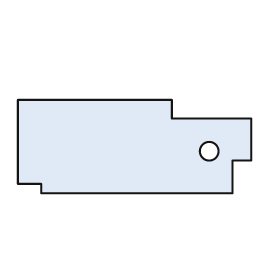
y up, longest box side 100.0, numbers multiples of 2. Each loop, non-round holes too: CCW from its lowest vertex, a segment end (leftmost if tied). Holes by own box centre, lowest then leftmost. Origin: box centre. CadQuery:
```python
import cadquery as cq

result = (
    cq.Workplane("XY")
    .moveTo(-40.0, -20.0)
    .lineTo(42.0, -20.0)
    .lineTo(42.0, -6.0)
    .lineTo(50.0, -6.0)
    .lineTo(50.0, 12.0)
    .lineTo(16.0, 12.0)
    .lineTo(16.0, 20.0)
    .lineTo(-50.0, 20.0)
    .lineTo(-50.0, -16.0)
    .lineTo(-40.0, -16.0)
    .close()
    .moveTo(32.0, -2.0)
    .circle(4.0)
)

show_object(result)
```